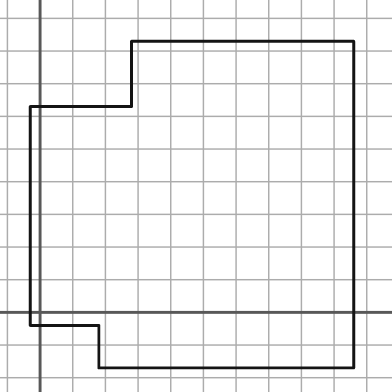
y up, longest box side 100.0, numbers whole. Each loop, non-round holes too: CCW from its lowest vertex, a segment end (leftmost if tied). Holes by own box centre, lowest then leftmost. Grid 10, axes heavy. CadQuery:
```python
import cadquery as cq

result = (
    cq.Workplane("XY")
    .moveTo(18.0, -17.0)
    .lineTo(96.0, -17.0)
    .lineTo(96.0, 83.0)
    .lineTo(28.0, 83.0)
    .lineTo(28.0, 63.0)
    .lineTo(-3.0, 63.0)
    .lineTo(-3.0, -4.0)
    .lineTo(18.0, -4.0)
    .close()
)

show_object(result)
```